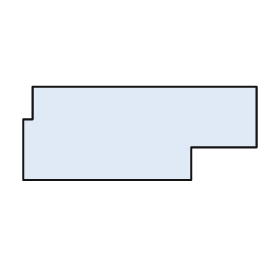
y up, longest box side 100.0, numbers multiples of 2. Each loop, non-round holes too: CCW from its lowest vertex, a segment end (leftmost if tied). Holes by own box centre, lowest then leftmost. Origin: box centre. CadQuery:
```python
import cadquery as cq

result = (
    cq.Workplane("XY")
    .moveTo(-50.0, -20.0)
    .lineTo(22.0, -20.0)
    .lineTo(22.0, -6.0)
    .lineTo(50.0, -6.0)
    .lineTo(50.0, 20.0)
    .lineTo(-46.0, 20.0)
    .lineTo(-46.0, 6.0)
    .lineTo(-50.0, 6.0)
    .close()
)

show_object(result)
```